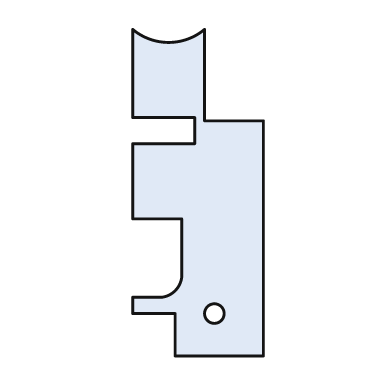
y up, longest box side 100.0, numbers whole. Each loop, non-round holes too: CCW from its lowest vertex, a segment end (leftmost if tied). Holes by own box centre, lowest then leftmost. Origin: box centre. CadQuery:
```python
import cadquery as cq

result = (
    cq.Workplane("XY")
    .moveTo(-7.0, -50.0)
    .lineTo(20.0, -50.0)
    .lineTo(20.0, 22.0)
    .lineTo(2.0, 22.0)
    .lineTo(2.0, 50.0)
    .threePointArc((-9.0, 46.0), (-20.0, 50.0))
    .lineTo(-20.0, 23.0)
    .lineTo(-1.0, 23.0)
    .lineTo(-1.0, 15.0)
    .lineTo(-20.0, 15.0)
    .lineTo(-20.0, -8.0)
    .lineTo(-5.0, -8.0)
    .lineTo(-5.0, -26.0)
    .threePointArc((-7.0, -30.0), (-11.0, -32.0))
    .lineTo(-20.0, -32.0)
    .lineTo(-20.0, -37.0)
    .lineTo(-7.0, -37.0)
    .close()
    .moveTo(5.0, -37.0)
    .circle(3.0)
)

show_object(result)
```